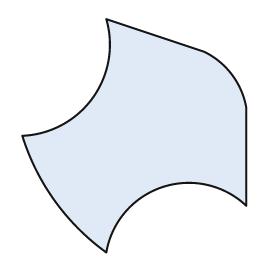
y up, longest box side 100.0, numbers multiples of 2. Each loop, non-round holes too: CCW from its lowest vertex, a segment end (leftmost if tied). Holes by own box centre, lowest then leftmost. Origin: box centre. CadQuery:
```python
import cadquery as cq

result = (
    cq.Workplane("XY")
    .moveTo(-12.0, -50.0)
    .threePointArc((12.0, -22.0), (48.0, -30.0))
    .lineTo(48.0, 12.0)
    .threePointArc((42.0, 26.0), (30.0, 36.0))
    .lineTo(-12.0, 50.0)
    .threePointArc((-18.0, 16.0), (-48.0, 0.0))
    .threePointArc((-34.0, -28.0), (-12.0, -50.0))
    .close()
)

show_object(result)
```